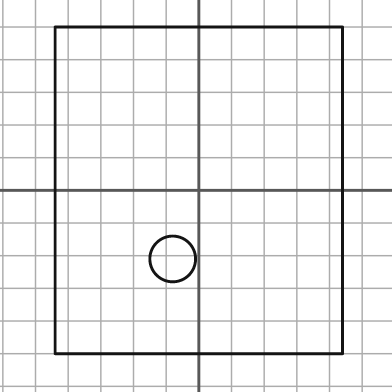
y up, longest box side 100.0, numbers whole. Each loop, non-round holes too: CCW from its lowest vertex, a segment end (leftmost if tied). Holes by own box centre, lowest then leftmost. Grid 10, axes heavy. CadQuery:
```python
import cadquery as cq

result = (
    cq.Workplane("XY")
    .moveTo(-44.0, -50.0)
    .lineTo(44.0, -50.0)
    .lineTo(44.0, 50.0)
    .lineTo(-44.0, 50.0)
    .close()
    .moveTo(-8.0, -21.0)
    .circle(7.0)
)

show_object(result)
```